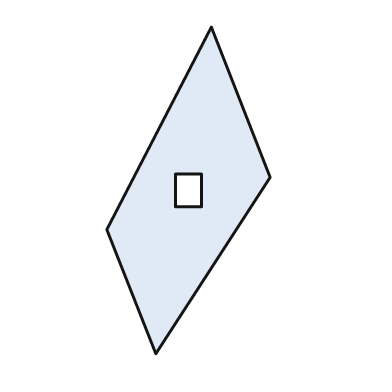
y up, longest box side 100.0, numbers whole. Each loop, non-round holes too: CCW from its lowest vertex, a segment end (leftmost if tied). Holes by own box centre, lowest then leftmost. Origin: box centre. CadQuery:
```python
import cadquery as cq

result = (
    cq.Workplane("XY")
    .moveTo(-10.0, -50.0)
    .lineTo(25.0, 4.0)
    .lineTo(7.0, 50.0)
    .lineTo(-25.0, -12.0)
    .close()
    .moveTo(-4.0, -5.0)
    .lineTo(4.0, -5.0)
    .lineTo(4.0, 5.0)
    .lineTo(-4.0, 5.0)
    .close()
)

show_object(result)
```